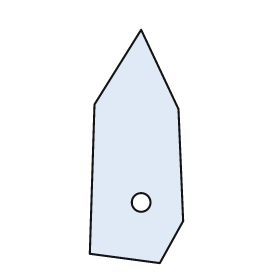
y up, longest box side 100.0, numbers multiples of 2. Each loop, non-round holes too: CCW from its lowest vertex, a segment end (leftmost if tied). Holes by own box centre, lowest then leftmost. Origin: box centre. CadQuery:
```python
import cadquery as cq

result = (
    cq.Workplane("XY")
    .moveTo(10.0, -50.0)
    .lineTo(20.0, -32.0)
    .lineTo(18.0, 16.0)
    .lineTo(2.0, 50.0)
    .lineTo(-18.0, 18.0)
    .lineTo(-20.0, -46.0)
    .close()
    .moveTo(2.0, -24.0)
    .circle(4.0)
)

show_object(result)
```